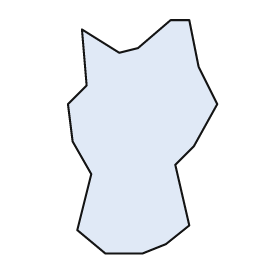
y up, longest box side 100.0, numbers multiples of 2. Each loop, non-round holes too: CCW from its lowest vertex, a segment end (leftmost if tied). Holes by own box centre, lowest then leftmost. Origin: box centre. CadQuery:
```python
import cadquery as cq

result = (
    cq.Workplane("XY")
    .moveTo(-16.0, -50.0)
    .lineTo(0.0, -50.0)
    .lineTo(10.0, -46.0)
    .lineTo(20.0, -38.0)
    .lineTo(14.0, -12.0)
    .lineTo(22.0, -4.0)
    .lineTo(32.0, 14.0)
    .lineTo(24.0, 30.0)
    .lineTo(20.0, 50.0)
    .lineTo(12.0, 50.0)
    .lineTo(-2.0, 38.0)
    .lineTo(-10.0, 36.0)
    .lineTo(-26.0, 46.0)
    .lineTo(-24.0, 22.0)
    .lineTo(-32.0, 14.0)
    .lineTo(-30.0, -2.0)
    .lineTo(-22.0, -16.0)
    .lineTo(-28.0, -40.0)
    .close()
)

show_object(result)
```